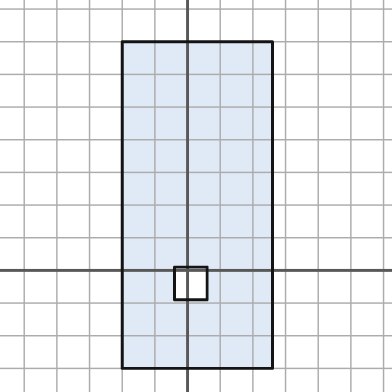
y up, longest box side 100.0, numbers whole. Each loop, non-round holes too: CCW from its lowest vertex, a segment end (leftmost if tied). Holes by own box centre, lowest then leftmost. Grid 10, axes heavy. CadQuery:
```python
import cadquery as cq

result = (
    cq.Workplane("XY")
    .moveTo(-20.0, -30.0)
    .lineTo(26.0, -30.0)
    .lineTo(26.0, 70.0)
    .lineTo(-20.0, 70.0)
    .close()
    .moveTo(-4.0, -9.0)
    .lineTo(6.0, -9.0)
    .lineTo(6.0, 1.0)
    .lineTo(-4.0, 1.0)
    .close()
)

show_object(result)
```